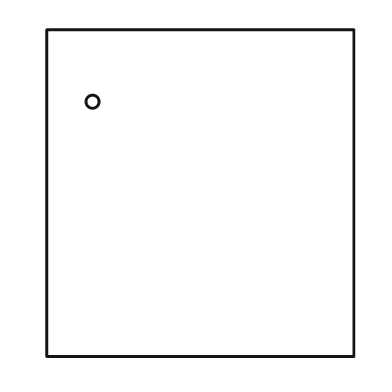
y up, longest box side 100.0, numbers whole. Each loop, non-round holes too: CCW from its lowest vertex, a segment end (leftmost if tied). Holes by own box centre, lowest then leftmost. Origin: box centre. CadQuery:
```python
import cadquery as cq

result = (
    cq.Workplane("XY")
    .moveTo(-47.0, -50.0)
    .lineTo(47.0, -50.0)
    .lineTo(47.0, 50.0)
    .lineTo(-47.0, 50.0)
    .close()
    .moveTo(-33.0, 28.0)
    .circle(2.0)
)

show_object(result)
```